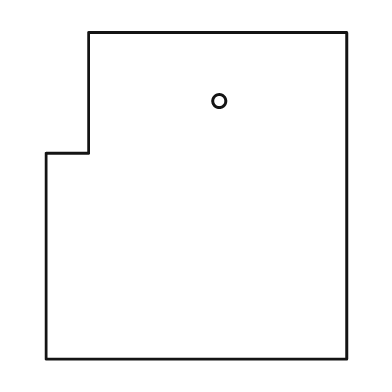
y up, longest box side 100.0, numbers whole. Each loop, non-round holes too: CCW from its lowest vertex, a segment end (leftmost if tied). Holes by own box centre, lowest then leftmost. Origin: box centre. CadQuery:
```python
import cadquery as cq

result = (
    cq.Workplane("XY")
    .moveTo(-46.0, -50.0)
    .lineTo(46.0, -50.0)
    .lineTo(46.0, 50.0)
    .lineTo(-33.0, 50.0)
    .lineTo(-33.0, 13.0)
    .lineTo(-46.0, 13.0)
    .close()
    .moveTo(7.0, 29.0)
    .circle(2.0)
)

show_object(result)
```